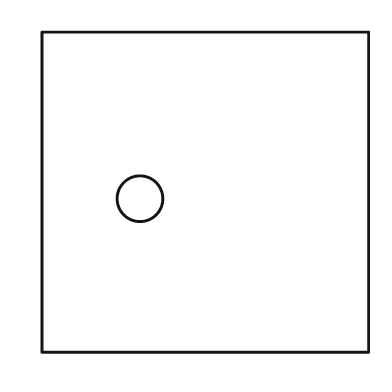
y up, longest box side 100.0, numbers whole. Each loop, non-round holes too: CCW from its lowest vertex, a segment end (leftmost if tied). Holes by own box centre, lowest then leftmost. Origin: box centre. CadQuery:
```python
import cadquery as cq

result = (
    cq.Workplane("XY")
    .moveTo(-50.0, -49.0)
    .lineTo(50.0, -49.0)
    .lineTo(50.0, 49.0)
    .lineTo(-50.0, 49.0)
    .close()
    .moveTo(-20.0, -2.0)
    .circle(7.0)
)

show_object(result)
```